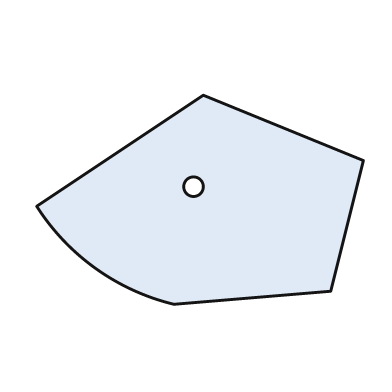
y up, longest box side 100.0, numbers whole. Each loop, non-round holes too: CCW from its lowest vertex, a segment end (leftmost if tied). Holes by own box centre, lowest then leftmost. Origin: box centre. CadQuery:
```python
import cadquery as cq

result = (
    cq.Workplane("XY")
    .moveTo(-8.0, -32.0)
    .lineTo(40.0, -28.0)
    .lineTo(50.0, 12.0)
    .lineTo(1.0, 32.0)
    .lineTo(-50.0, -2.0)
    .threePointArc((-32.0, -21.0), (-8.0, -32.0))
    .close()
    .moveTo(-2.0, 4.0)
    .circle(3.0)
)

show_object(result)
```